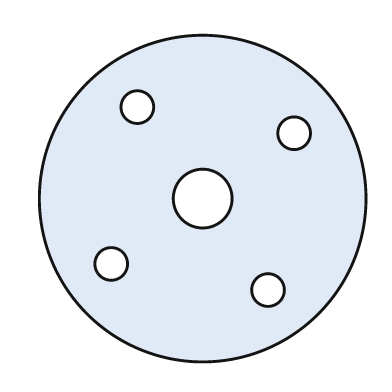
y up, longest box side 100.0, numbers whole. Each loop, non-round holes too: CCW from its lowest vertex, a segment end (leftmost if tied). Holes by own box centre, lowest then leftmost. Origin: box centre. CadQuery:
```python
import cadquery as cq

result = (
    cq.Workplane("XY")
    .moveTo(0.0, 0.0)
    .circle(50.0)
    .moveTo(20.0, -28.0)
    .circle(5.0)
    .moveTo(-28.0, -20.0)
    .circle(5.0)
    .moveTo(0.0, 0.0)
    .circle(9.0)
    .moveTo(28.0, 20.0)
    .circle(5.0)
    .moveTo(-20.0, 28.0)
    .circle(5.0)
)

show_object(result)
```